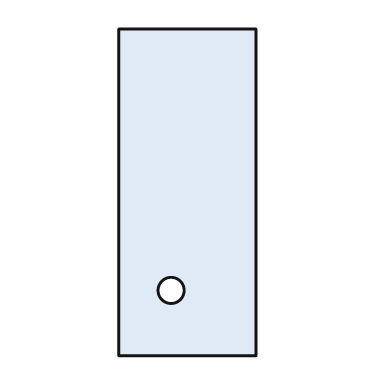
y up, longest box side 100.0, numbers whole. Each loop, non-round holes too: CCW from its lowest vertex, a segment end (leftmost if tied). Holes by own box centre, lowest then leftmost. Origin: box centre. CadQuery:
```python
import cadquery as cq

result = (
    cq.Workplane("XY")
    .moveTo(-21.0, -50.0)
    .lineTo(21.0, -50.0)
    .lineTo(21.0, 50.0)
    .lineTo(-21.0, 50.0)
    .close()
    .moveTo(-5.0, -30.0)
    .circle(4.0)
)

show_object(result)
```